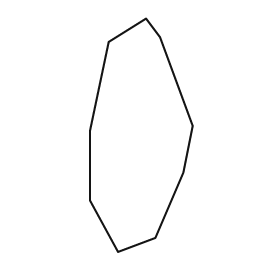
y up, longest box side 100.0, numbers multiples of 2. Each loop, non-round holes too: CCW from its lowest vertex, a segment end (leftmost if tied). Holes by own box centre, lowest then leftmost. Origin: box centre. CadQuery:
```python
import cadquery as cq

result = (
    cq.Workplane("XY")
    .moveTo(-10.0, -50.0)
    .lineTo(6.0, -44.0)
    .lineTo(18.0, -16.0)
    .lineTo(22.0, 4.0)
    .lineTo(8.0, 42.0)
    .lineTo(2.0, 50.0)
    .lineTo(-14.0, 40.0)
    .lineTo(-22.0, 2.0)
    .lineTo(-22.0, -28.0)
    .close()
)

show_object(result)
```